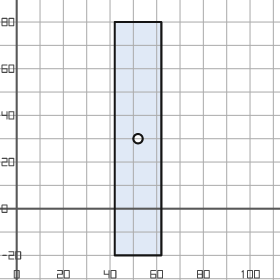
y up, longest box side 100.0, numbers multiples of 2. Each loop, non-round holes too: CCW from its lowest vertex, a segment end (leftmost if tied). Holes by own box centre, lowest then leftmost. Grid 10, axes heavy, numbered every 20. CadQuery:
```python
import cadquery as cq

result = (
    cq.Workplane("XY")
    .moveTo(42.0, -20.0)
    .lineTo(62.0, -20.0)
    .lineTo(62.0, 80.0)
    .lineTo(42.0, 80.0)
    .close()
    .moveTo(52.0, 30.0)
    .circle(2.0)
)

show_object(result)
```